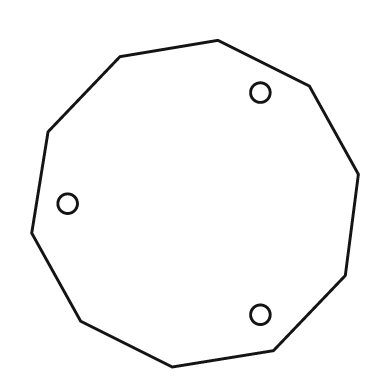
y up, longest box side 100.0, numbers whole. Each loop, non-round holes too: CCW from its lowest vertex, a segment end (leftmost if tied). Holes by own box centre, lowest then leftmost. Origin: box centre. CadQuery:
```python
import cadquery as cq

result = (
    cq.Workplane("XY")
    .moveTo(-7.0, -50.0)
    .lineTo(24.0, -45.0)
    .lineTo(46.0, -22.0)
    .lineTo(50.0, 9.0)
    .lineTo(35.0, 36.0)
    .lineTo(7.0, 50.0)
    .lineTo(-23.0, 45.0)
    .lineTo(-45.0, 22.0)
    .lineTo(-50.0, -9.0)
    .lineTo(-35.0, -36.0)
    .close()
    .moveTo(20.0, -34.0)
    .circle(3.0)
    .moveTo(-39.0, 0.0)
    .circle(3.0)
    .moveTo(20.0, 34.0)
    .circle(3.0)
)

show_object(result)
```